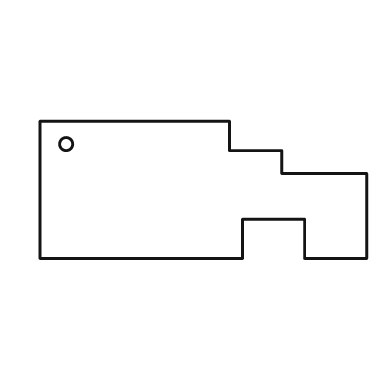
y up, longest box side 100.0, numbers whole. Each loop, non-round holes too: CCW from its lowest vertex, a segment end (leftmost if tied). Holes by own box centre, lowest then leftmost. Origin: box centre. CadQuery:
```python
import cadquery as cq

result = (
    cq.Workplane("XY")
    .moveTo(-50.0, -21.0)
    .lineTo(12.0, -21.0)
    .lineTo(12.0, -9.0)
    .lineTo(31.0, -9.0)
    .lineTo(31.0, -21.0)
    .lineTo(50.0, -21.0)
    .lineTo(50.0, 5.0)
    .lineTo(24.0, 5.0)
    .lineTo(24.0, 12.0)
    .lineTo(8.0, 12.0)
    .lineTo(8.0, 21.0)
    .lineTo(-50.0, 21.0)
    .close()
    .moveTo(-42.0, 14.0)
    .circle(2.0)
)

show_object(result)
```